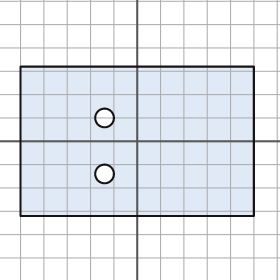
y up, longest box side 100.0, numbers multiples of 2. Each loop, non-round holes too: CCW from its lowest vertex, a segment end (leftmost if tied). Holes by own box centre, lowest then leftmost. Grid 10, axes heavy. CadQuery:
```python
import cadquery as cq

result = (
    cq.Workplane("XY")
    .moveTo(-50.0, -32.0)
    .lineTo(50.0, -32.0)
    .lineTo(50.0, 32.0)
    .lineTo(-50.0, 32.0)
    .close()
    .moveTo(-14.0, -14.0)
    .circle(4.0)
    .moveTo(-14.0, 10.0)
    .circle(4.0)
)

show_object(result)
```